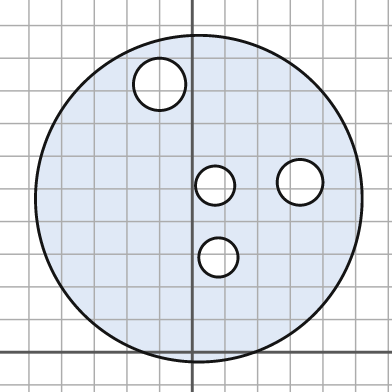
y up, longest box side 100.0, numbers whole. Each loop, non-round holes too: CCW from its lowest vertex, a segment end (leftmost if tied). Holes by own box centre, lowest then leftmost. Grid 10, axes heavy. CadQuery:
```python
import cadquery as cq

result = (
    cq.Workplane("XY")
    .moveTo(2.0, 47.0)
    .circle(50.0)
    .moveTo(8.0, 29.0)
    .circle(6.0)
    .moveTo(7.0, 51.0)
    .circle(6.0)
    .moveTo(33.0, 52.0)
    .circle(7.0)
    .moveTo(-10.0, 82.0)
    .circle(8.0)
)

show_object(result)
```